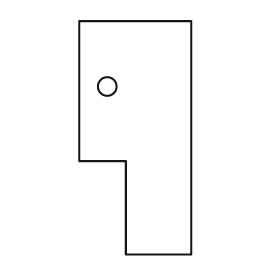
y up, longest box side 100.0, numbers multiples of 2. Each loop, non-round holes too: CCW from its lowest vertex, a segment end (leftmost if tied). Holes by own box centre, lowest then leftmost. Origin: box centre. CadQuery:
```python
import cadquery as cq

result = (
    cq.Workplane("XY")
    .moveTo(-4.0, -50.0)
    .lineTo(24.0, -50.0)
    .lineTo(24.0, 50.0)
    .lineTo(-24.0, 50.0)
    .lineTo(-24.0, -10.0)
    .lineTo(-4.0, -10.0)
    .close()
    .moveTo(-12.0, 22.0)
    .circle(4.0)
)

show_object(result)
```